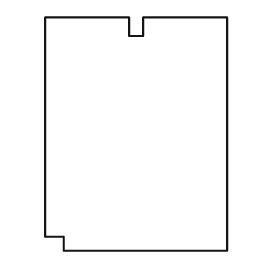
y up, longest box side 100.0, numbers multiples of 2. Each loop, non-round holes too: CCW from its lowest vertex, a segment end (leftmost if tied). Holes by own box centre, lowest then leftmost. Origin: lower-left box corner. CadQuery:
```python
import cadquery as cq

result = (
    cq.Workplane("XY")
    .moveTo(8.0, 0.0)
    .lineTo(78.0, 0.0)
    .lineTo(78.0, 100.0)
    .lineTo(42.0, 100.0)
    .lineTo(42.0, 92.0)
    .lineTo(36.0, 92.0)
    .lineTo(36.0, 100.0)
    .lineTo(0.0, 100.0)
    .lineTo(0.0, 6.0)
    .lineTo(8.0, 6.0)
    .close()
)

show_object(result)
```